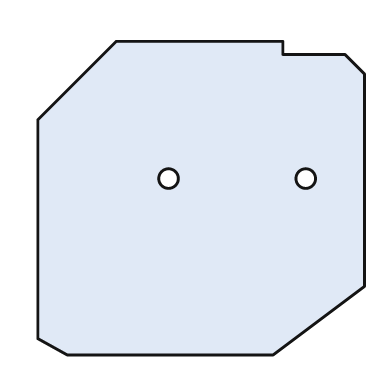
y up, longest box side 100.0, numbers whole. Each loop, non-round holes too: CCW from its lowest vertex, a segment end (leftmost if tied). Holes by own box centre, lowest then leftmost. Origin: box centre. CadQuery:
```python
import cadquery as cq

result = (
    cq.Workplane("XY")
    .moveTo(-41.0, -48.0)
    .lineTo(22.0, -48.0)
    .lineTo(50.0, -27.0)
    .lineTo(50.0, 38.0)
    .lineTo(44.0, 44.0)
    .lineTo(25.0, 44.0)
    .lineTo(25.0, 48.0)
    .lineTo(-26.0, 48.0)
    .lineTo(-50.0, 24.0)
    .lineTo(-50.0, -43.0)
    .close()
    .moveTo(-10.0, 6.0)
    .circle(3.0)
    .moveTo(32.0, 6.0)
    .circle(3.0)
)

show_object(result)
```